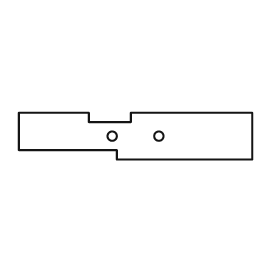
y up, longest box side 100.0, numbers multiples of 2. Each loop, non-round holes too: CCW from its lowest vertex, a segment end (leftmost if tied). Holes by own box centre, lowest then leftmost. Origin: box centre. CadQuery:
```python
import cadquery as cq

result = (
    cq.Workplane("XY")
    .moveTo(-8.0, -10.0)
    .lineTo(50.0, -10.0)
    .lineTo(50.0, 10.0)
    .lineTo(-2.0, 10.0)
    .lineTo(-2.0, 6.0)
    .lineTo(-20.0, 6.0)
    .lineTo(-20.0, 10.0)
    .lineTo(-50.0, 10.0)
    .lineTo(-50.0, -6.0)
    .lineTo(-8.0, -6.0)
    .close()
    .moveTo(-10.0, 0.0)
    .circle(2.0)
    .moveTo(10.0, 0.0)
    .circle(2.0)
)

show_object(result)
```